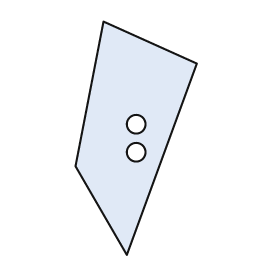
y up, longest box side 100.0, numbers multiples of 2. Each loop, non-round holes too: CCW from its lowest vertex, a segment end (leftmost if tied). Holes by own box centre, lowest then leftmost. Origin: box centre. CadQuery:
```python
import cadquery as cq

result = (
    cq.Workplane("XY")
    .moveTo(-4.0, -50.0)
    .lineTo(26.0, 32.0)
    .lineTo(-14.0, 50.0)
    .lineTo(-26.0, -12.0)
    .close()
    .moveTo(0.0, -6.0)
    .circle(4.0)
    .moveTo(0.0, 6.0)
    .circle(4.0)
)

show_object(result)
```